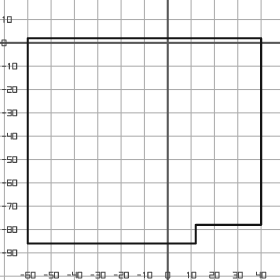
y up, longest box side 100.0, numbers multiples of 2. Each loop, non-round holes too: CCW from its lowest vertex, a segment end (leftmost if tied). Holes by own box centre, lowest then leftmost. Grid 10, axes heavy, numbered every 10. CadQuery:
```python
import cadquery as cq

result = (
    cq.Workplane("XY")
    .moveTo(-60.0, -86.0)
    .lineTo(12.0, -86.0)
    .lineTo(12.0, -78.0)
    .lineTo(40.0, -78.0)
    .lineTo(40.0, 2.0)
    .lineTo(-60.0, 2.0)
    .close()
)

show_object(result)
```